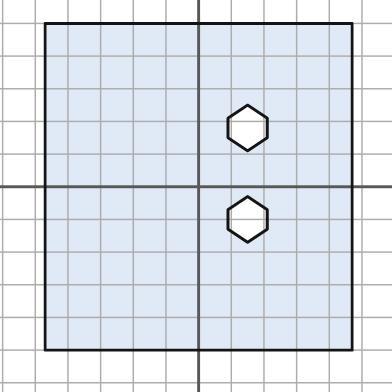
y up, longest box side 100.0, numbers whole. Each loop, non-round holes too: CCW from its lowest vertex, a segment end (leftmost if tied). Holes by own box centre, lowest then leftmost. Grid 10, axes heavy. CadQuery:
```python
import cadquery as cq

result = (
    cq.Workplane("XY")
    .moveTo(-47.0, -50.0)
    .lineTo(47.0, -50.0)
    .lineTo(47.0, 50.0)
    .lineTo(-47.0, 50.0)
    .close()
    .moveTo(15.0, -17.0)
    .lineTo(21.0, -13.0)
    .lineTo(21.0, -7.0)
    .lineTo(15.0, -3.0)
    .lineTo(9.0, -7.0)
    .lineTo(9.0, -13.0)
    .close()
    .moveTo(15.0, 11.0)
    .lineTo(21.0, 15.0)
    .lineTo(21.0, 21.0)
    .lineTo(15.0, 25.0)
    .lineTo(9.0, 21.0)
    .lineTo(9.0, 15.0)
    .close()
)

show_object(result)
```